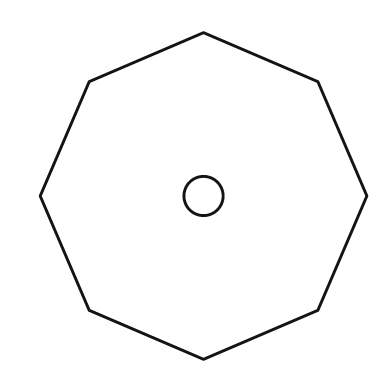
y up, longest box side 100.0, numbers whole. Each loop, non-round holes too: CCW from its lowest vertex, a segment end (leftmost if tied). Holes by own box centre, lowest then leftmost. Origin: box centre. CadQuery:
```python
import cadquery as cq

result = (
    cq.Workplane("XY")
    .moveTo(0.0, -50.0)
    .lineTo(35.0, -35.0)
    .lineTo(50.0, 0.0)
    .lineTo(35.0, 35.0)
    .lineTo(0.0, 50.0)
    .lineTo(-35.0, 35.0)
    .lineTo(-50.0, 0.0)
    .lineTo(-35.0, -35.0)
    .close()
    .moveTo(0.0, 0.0)
    .circle(6.0)
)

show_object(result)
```